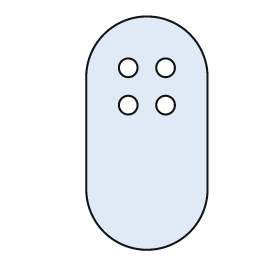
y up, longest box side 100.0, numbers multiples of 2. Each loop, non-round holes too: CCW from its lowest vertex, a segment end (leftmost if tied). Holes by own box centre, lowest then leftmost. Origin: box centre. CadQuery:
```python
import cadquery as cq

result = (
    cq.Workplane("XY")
    .moveTo(-26.0, -24.0)
    .threePointArc((0.0, -50.0), (26.0, -24.0))
    .lineTo(26.0, 24.0)
    .threePointArc((0.0, 50.0), (-26.0, 24.0))
    .close()
    .moveTo(-8.0, 12.0)
    .circle(4.0)
    .moveTo(8.0, 12.0)
    .circle(4.0)
    .moveTo(-8.0, 28.0)
    .circle(4.0)
    .moveTo(8.0, 28.0)
    .circle(4.0)
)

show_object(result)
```